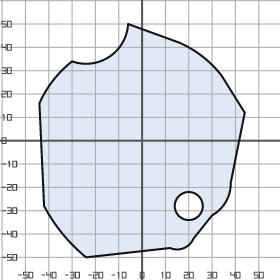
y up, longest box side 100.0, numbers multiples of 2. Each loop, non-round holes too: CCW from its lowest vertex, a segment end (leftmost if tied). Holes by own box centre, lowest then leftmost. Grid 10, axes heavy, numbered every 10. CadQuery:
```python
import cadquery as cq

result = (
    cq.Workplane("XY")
    .moveTo(-24.0, -50.0)
    .lineTo(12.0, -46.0)
    .threePointArc((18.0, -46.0), (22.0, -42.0))
    .lineTo(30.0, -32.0)
    .threePointArc((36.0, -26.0), (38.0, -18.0))
    .lineTo(44.0, 12.0)
    .lineTo(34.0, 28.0)
    .threePointArc((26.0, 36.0), (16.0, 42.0))
    .lineTo(-6.0, 50.0)
    .threePointArc((-14.0, 36.0), (-30.0, 34.0))
    .threePointArc((-38.0, 26.0), (-44.0, 16.0))
    .lineTo(-42.0, -28.0)
    .threePointArc((-34.0, -40.0), (-24.0, -50.0))
    .close()
    .moveTo(20.0, -28.0)
    .circle(6.0)
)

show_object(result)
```